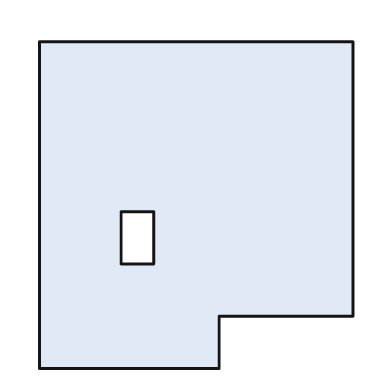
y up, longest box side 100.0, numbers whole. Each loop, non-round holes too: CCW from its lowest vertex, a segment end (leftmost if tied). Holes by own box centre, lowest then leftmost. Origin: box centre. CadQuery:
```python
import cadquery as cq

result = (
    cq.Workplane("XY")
    .moveTo(-48.0, -50.0)
    .lineTo(7.0, -50.0)
    .lineTo(7.0, -34.0)
    .lineTo(48.0, -34.0)
    .lineTo(48.0, 50.0)
    .lineTo(-48.0, 50.0)
    .close()
    .moveTo(-23.0, -18.0)
    .lineTo(-13.0, -18.0)
    .lineTo(-13.0, -2.0)
    .lineTo(-23.0, -2.0)
    .close()
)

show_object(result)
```